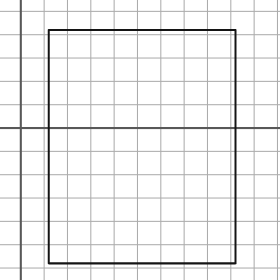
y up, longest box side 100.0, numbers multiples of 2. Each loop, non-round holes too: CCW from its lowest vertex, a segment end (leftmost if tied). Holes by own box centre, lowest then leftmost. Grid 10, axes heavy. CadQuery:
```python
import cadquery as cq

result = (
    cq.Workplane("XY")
    .moveTo(12.0, -58.0)
    .lineTo(92.0, -58.0)
    .lineTo(92.0, 42.0)
    .lineTo(12.0, 42.0)
    .close()
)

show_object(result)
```